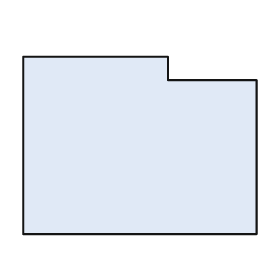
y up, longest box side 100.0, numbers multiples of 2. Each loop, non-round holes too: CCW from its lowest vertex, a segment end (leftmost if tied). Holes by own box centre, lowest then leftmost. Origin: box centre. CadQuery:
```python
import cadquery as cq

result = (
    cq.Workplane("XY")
    .moveTo(-50.0, -38.0)
    .lineTo(50.0, -38.0)
    .lineTo(50.0, 28.0)
    .lineTo(12.0, 28.0)
    .lineTo(12.0, 38.0)
    .lineTo(-50.0, 38.0)
    .close()
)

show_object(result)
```